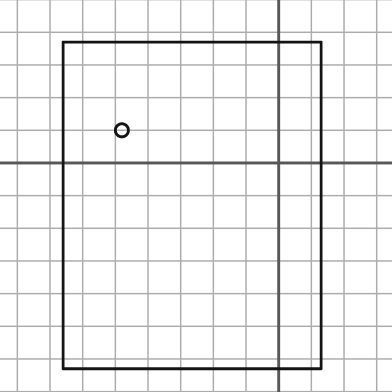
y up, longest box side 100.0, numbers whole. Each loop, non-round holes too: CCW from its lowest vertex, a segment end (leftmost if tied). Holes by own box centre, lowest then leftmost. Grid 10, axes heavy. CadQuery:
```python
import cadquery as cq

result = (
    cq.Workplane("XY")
    .moveTo(-66.0, -63.0)
    .lineTo(13.0, -63.0)
    .lineTo(13.0, 37.0)
    .lineTo(-66.0, 37.0)
    .close()
    .moveTo(-48.0, 10.0)
    .circle(2.0)
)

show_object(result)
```